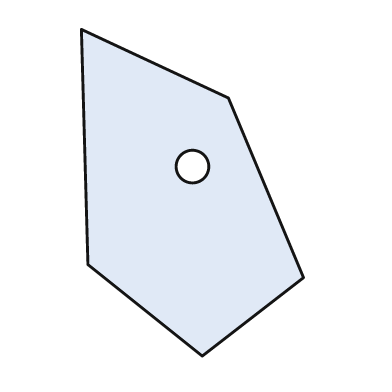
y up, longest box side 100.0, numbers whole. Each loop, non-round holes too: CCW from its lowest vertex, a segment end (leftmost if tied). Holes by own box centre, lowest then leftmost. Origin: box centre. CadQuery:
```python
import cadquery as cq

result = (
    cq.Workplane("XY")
    .moveTo(3.0, -50.0)
    .lineTo(34.0, -26.0)
    .lineTo(11.0, 29.0)
    .lineTo(-34.0, 50.0)
    .lineTo(-32.0, -22.0)
    .close()
    .moveTo(0.0, 8.0)
    .circle(5.0)
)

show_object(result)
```